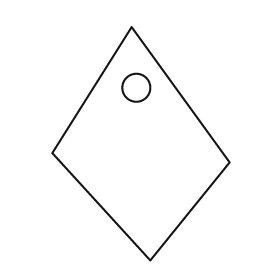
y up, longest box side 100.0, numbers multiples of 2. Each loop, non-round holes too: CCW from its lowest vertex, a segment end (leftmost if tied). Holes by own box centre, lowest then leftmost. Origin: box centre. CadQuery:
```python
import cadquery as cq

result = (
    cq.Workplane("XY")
    .moveTo(4.0, -50.0)
    .lineTo(38.0, -8.0)
    .lineTo(-4.0, 50.0)
    .lineTo(-38.0, -4.0)
    .close()
    .moveTo(-2.0, 24.0)
    .circle(6.0)
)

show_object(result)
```